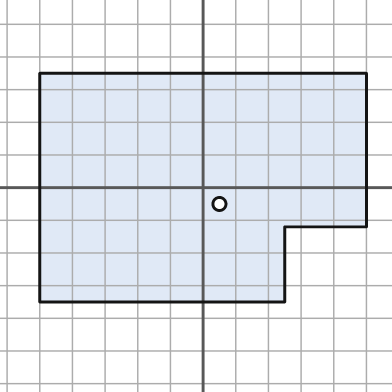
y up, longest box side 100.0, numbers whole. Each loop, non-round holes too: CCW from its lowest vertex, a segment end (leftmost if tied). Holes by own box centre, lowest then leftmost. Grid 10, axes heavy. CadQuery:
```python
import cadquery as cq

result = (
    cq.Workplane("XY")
    .moveTo(-50.0, -35.0)
    .lineTo(25.0, -35.0)
    .lineTo(25.0, -12.0)
    .lineTo(50.0, -12.0)
    .lineTo(50.0, 35.0)
    .lineTo(-50.0, 35.0)
    .close()
    .moveTo(5.0, -5.0)
    .circle(2.0)
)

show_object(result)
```